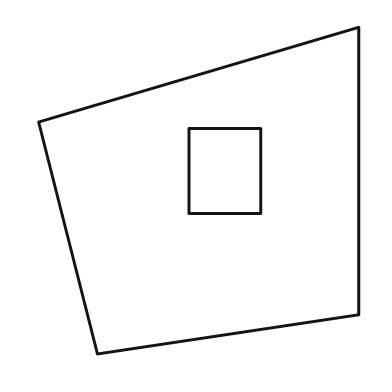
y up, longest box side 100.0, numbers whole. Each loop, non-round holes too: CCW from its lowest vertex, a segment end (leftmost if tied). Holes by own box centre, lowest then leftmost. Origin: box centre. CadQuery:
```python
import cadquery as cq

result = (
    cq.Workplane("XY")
    .moveTo(-31.0, -50.0)
    .lineTo(49.0, -38.0)
    .lineTo(49.0, 50.0)
    .lineTo(-49.0, 21.0)
    .close()
    .moveTo(-3.0, -7.0)
    .lineTo(19.0, -7.0)
    .lineTo(19.0, 19.0)
    .lineTo(-3.0, 19.0)
    .close()
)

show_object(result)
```